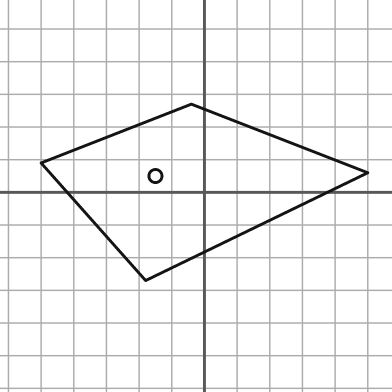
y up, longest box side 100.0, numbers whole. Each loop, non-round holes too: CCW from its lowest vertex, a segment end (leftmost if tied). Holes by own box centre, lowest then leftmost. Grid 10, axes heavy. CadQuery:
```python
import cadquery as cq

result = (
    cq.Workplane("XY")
    .moveTo(-18.0, -27.0)
    .lineTo(50.0, 6.0)
    .lineTo(-4.0, 27.0)
    .lineTo(-50.0, 9.0)
    .close()
    .moveTo(-15.0, 5.0)
    .circle(2.0)
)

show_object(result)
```